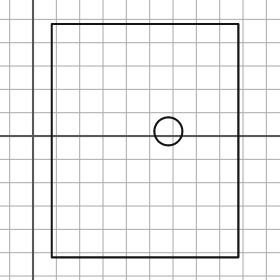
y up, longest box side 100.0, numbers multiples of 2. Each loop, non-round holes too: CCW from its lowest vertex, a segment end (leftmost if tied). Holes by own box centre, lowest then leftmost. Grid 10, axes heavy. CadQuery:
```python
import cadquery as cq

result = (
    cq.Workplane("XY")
    .moveTo(8.0, -52.0)
    .lineTo(88.0, -52.0)
    .lineTo(88.0, 48.0)
    .lineTo(8.0, 48.0)
    .close()
    .moveTo(58.0, 2.0)
    .circle(6.0)
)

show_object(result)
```